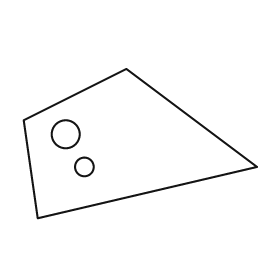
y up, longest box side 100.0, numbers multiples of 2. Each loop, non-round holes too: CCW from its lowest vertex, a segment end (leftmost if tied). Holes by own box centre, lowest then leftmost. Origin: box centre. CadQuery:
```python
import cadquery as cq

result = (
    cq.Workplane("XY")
    .moveTo(-44.0, -32.0)
    .lineTo(50.0, -10.0)
    .lineTo(-6.0, 32.0)
    .lineTo(-50.0, 10.0)
    .close()
    .moveTo(-24.0, -10.0)
    .circle(4.0)
    .moveTo(-32.0, 4.0)
    .circle(6.0)
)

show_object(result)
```